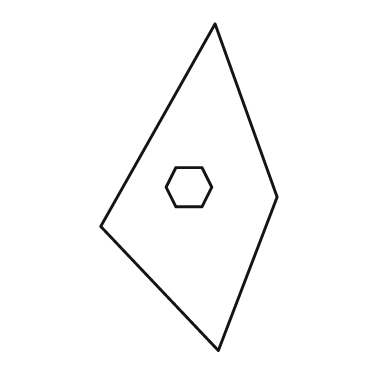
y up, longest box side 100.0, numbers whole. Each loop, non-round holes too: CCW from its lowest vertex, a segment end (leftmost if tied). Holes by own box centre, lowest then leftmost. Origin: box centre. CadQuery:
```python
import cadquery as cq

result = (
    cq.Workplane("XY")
    .moveTo(9.0, -50.0)
    .lineTo(27.0, -3.0)
    .lineTo(8.0, 50.0)
    .lineTo(-27.0, -12.0)
    .close()
    .moveTo(-4.0, -6.0)
    .lineTo(4.0, -6.0)
    .lineTo(7.0, 0.0)
    .lineTo(4.0, 6.0)
    .lineTo(-4.0, 6.0)
    .lineTo(-7.0, 0.0)
    .close()
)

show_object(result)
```